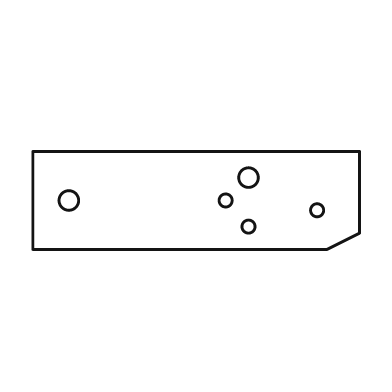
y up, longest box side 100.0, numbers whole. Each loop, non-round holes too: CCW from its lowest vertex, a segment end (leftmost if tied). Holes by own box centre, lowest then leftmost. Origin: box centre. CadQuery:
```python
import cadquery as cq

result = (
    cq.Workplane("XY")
    .moveTo(-50.0, -15.0)
    .lineTo(40.0, -15.0)
    .lineTo(50.0, -10.0)
    .lineTo(50.0, 15.0)
    .lineTo(-50.0, 15.0)
    .close()
    .moveTo(16.0, -8.0)
    .circle(2.0)
    .moveTo(37.0, -3.0)
    .circle(2.0)
    .moveTo(-39.0, 0.0)
    .circle(3.0)
    .moveTo(9.0, 0.0)
    .circle(2.0)
    .moveTo(16.0, 7.0)
    .circle(3.0)
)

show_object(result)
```